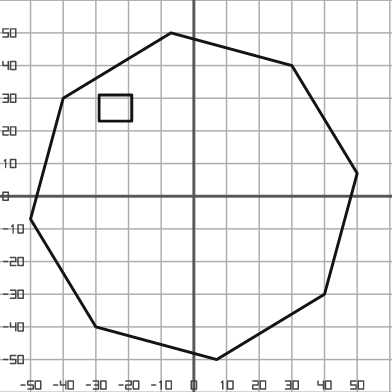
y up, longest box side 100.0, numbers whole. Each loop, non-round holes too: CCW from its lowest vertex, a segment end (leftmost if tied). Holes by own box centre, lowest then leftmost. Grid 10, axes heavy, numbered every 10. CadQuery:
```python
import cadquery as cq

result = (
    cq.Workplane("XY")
    .moveTo(7.0, -50.0)
    .lineTo(40.0, -30.0)
    .lineTo(50.0, 7.0)
    .lineTo(30.0, 40.0)
    .lineTo(-7.0, 50.0)
    .lineTo(-40.0, 30.0)
    .lineTo(-50.0, -7.0)
    .lineTo(-30.0, -40.0)
    .close()
    .moveTo(-29.0, 23.0)
    .lineTo(-19.0, 23.0)
    .lineTo(-19.0, 31.0)
    .lineTo(-29.0, 31.0)
    .close()
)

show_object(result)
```